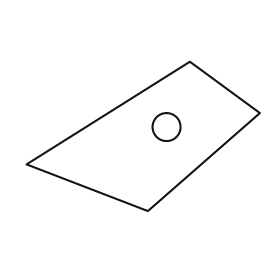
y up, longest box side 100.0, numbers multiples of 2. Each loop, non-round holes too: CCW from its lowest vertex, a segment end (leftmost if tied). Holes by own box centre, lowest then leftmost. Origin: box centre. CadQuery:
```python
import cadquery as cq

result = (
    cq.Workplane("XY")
    .moveTo(2.0, -32.0)
    .lineTo(50.0, 10.0)
    .lineTo(20.0, 32.0)
    .lineTo(-50.0, -12.0)
    .close()
    .moveTo(10.0, 4.0)
    .circle(6.0)
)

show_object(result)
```